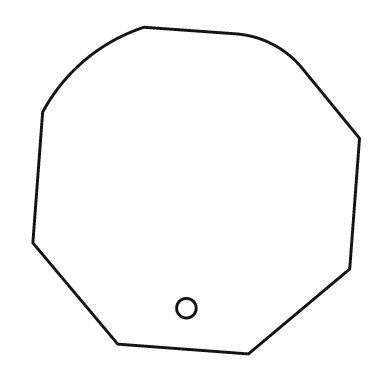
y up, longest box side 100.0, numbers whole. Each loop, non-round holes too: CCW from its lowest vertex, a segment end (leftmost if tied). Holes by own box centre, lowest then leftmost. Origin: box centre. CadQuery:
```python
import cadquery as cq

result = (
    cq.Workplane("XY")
    .moveTo(16.0, -50.0)
    .lineTo(47.0, -24.0)
    .lineTo(50.0, 16.0)
    .lineTo(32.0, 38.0)
    .threePointArc((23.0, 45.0), (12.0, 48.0))
    .lineTo(-16.0, 50.0)
    .threePointArc((-34.0, 40.0), (-47.0, 24.0))
    .lineTo(-50.0, -16.0)
    .lineTo(-24.0, -47.0)
    .close()
    .moveTo(-3.0, -36.0)
    .circle(3.0)
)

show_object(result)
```